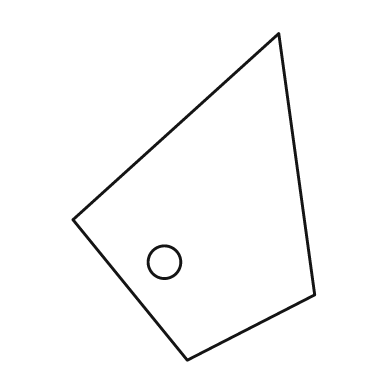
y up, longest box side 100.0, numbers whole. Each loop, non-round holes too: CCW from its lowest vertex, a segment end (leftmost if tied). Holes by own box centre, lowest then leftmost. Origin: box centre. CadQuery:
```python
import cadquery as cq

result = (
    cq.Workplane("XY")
    .moveTo(-2.0, -50.0)
    .lineTo(37.0, -30.0)
    .lineTo(26.0, 50.0)
    .lineTo(-37.0, -7.0)
    .close()
    .moveTo(-9.0, -20.0)
    .circle(5.0)
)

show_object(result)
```